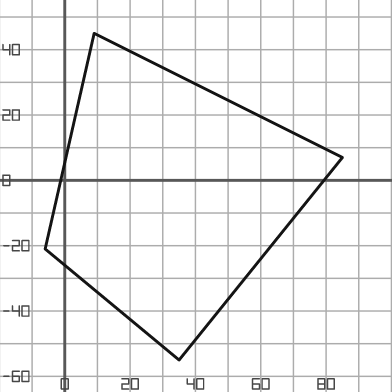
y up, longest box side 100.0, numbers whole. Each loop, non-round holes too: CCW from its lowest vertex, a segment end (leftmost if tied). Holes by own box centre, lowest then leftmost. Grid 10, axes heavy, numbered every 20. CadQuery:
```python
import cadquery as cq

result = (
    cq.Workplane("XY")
    .moveTo(35.0, -55.0)
    .lineTo(85.0, 7.0)
    .lineTo(9.0, 45.0)
    .lineTo(-6.0, -21.0)
    .close()
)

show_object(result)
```